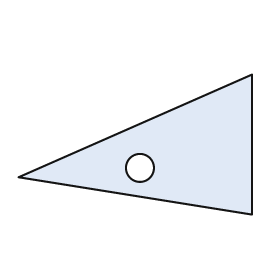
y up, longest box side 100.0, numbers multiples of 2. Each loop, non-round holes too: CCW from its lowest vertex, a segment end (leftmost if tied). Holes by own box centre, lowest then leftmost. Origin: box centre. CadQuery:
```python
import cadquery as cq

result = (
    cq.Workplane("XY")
    .moveTo(50.0, -30.0)
    .lineTo(50.0, 30.0)
    .lineTo(-50.0, -14.0)
    .close()
    .moveTo(2.0, -10.0)
    .circle(6.0)
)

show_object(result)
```